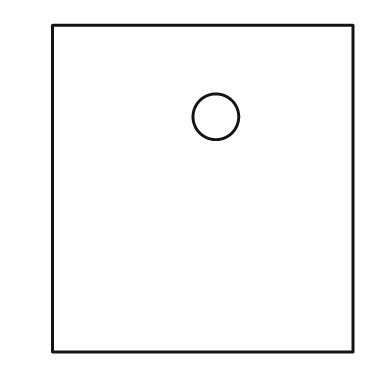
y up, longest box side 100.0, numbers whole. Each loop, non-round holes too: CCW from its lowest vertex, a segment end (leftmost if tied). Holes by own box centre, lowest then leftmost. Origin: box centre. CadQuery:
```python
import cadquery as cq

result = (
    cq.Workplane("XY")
    .moveTo(-46.0, -50.0)
    .lineTo(46.0, -50.0)
    .lineTo(46.0, 50.0)
    .lineTo(-46.0, 50.0)
    .close()
    .moveTo(4.0, 22.0)
    .circle(7.0)
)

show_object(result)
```